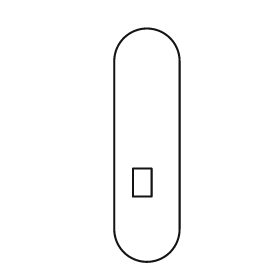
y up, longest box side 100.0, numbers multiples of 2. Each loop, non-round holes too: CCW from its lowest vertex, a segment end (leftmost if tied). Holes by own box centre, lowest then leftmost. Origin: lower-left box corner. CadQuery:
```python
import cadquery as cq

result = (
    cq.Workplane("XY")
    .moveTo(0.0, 14.0)
    .threePointArc((14.0, 0.0), (28.0, 14.0))
    .lineTo(28.0, 86.0)
    .threePointArc((14.0, 100.0), (0.0, 86.0))
    .close()
    .moveTo(8.0, 28.0)
    .lineTo(16.0, 28.0)
    .lineTo(16.0, 40.0)
    .lineTo(8.0, 40.0)
    .close()
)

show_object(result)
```